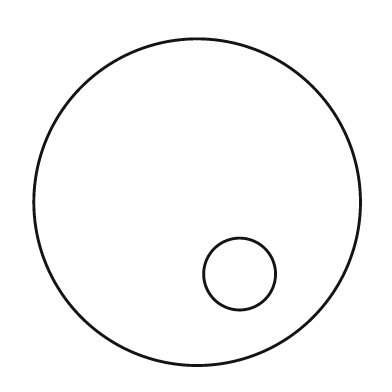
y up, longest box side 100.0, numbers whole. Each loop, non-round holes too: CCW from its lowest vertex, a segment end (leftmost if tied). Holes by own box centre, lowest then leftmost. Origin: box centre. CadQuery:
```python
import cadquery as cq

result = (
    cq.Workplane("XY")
    .moveTo(0.0, 0.0)
    .circle(50.0)
    .moveTo(13.0, -22.0)
    .circle(11.0)
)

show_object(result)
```